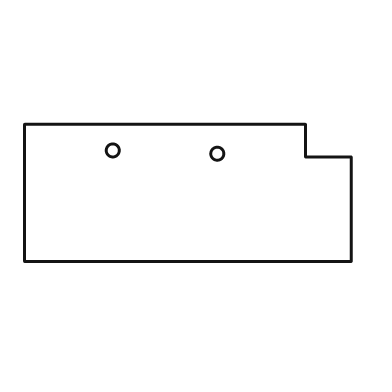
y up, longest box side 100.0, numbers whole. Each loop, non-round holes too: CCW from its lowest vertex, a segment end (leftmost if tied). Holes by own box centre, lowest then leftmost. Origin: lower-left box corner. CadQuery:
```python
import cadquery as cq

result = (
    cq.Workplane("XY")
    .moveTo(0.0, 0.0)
    .lineTo(100.0, 0.0)
    .lineTo(100.0, 32.0)
    .lineTo(86.0, 32.0)
    .lineTo(86.0, 42.0)
    .lineTo(0.0, 42.0)
    .close()
    .moveTo(59.0, 33.0)
    .circle(2.0)
    .moveTo(27.0, 34.0)
    .circle(2.0)
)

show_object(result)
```